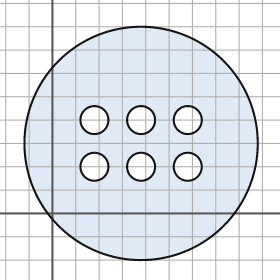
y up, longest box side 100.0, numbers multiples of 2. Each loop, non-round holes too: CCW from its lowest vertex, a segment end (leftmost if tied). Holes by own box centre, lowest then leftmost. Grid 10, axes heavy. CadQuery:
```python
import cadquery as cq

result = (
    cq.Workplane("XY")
    .moveTo(38.0, 30.0)
    .circle(50.0)
    .moveTo(18.0, 20.0)
    .circle(6.0)
    .moveTo(38.0, 20.0)
    .circle(6.0)
    .moveTo(58.0, 20.0)
    .circle(6.0)
    .moveTo(18.0, 40.0)
    .circle(6.0)
    .moveTo(38.0, 40.0)
    .circle(6.0)
    .moveTo(58.0, 40.0)
    .circle(6.0)
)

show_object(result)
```